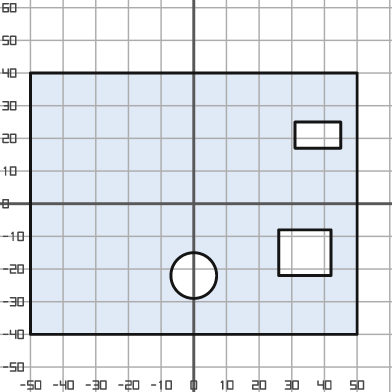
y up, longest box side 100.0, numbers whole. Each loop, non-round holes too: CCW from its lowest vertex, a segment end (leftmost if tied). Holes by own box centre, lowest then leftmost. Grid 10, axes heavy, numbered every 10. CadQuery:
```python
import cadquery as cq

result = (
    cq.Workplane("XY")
    .moveTo(-50.0, -40.0)
    .lineTo(50.0, -40.0)
    .lineTo(50.0, 40.0)
    .lineTo(-50.0, 40.0)
    .close()
    .moveTo(0.0, -22.0)
    .circle(7.0)
    .moveTo(26.0, -22.0)
    .lineTo(42.0, -22.0)
    .lineTo(42.0, -8.0)
    .lineTo(26.0, -8.0)
    .close()
    .moveTo(31.0, 17.0)
    .lineTo(45.0, 17.0)
    .lineTo(45.0, 25.0)
    .lineTo(31.0, 25.0)
    .close()
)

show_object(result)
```